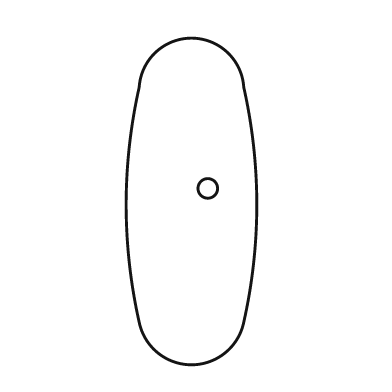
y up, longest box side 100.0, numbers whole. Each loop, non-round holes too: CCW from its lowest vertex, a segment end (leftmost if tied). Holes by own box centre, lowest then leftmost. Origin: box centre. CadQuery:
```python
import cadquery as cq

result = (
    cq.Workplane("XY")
    .moveTo(-16.0, -37.0)
    .threePointArc((0.0, -50.0), (16.0, -37.0))
    .threePointArc((20.0, -1.0), (16.0, 35.0))
    .threePointArc((0.0, 50.0), (-16.0, 35.0))
    .threePointArc((-20.0, -1.0), (-16.0, -37.0))
    .close()
    .moveTo(5.0, 4.0)
    .circle(3.0)
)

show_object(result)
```